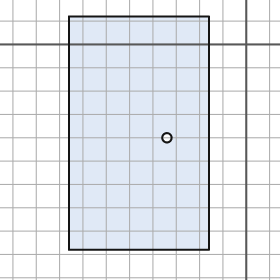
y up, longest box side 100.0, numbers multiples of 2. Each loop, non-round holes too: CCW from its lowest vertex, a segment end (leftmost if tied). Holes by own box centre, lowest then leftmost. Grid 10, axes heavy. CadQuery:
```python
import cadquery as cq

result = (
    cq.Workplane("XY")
    .moveTo(-76.0, -88.0)
    .lineTo(-16.0, -88.0)
    .lineTo(-16.0, 12.0)
    .lineTo(-76.0, 12.0)
    .close()
    .moveTo(-34.0, -40.0)
    .circle(2.0)
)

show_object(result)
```